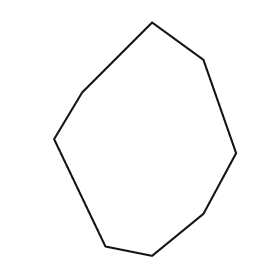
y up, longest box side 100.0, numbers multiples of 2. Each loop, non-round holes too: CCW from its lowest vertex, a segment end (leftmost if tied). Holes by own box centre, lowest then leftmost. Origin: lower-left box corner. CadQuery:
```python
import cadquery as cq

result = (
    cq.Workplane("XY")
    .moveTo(42.0, 0.0)
    .lineTo(64.0, 18.0)
    .lineTo(78.0, 44.0)
    .lineTo(64.0, 84.0)
    .lineTo(42.0, 100.0)
    .lineTo(12.0, 70.0)
    .lineTo(0.0, 50.0)
    .lineTo(22.0, 4.0)
    .close()
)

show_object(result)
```